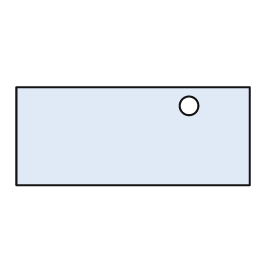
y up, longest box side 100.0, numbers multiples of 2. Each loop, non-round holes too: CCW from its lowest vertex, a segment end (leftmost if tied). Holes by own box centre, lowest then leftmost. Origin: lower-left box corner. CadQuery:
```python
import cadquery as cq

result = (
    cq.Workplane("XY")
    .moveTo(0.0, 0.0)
    .lineTo(100.0, 0.0)
    .lineTo(100.0, 42.0)
    .lineTo(0.0, 42.0)
    .close()
    .moveTo(74.0, 34.0)
    .circle(4.0)
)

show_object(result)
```